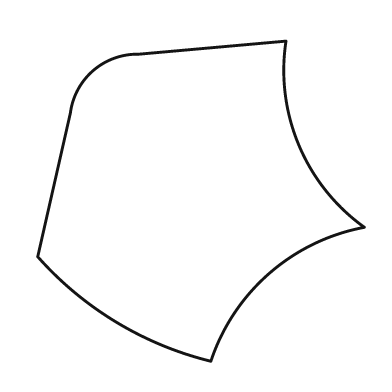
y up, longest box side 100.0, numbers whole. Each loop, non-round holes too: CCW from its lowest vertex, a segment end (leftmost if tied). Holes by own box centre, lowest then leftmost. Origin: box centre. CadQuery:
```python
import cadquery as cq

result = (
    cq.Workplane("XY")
    .moveTo(3.0, -49.0)
    .threePointArc((21.0, -22.0), (50.0, -8.0))
    .threePointArc((30.0, 17.0), (26.0, 49.0))
    .lineTo(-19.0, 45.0)
    .threePointArc((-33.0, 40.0), (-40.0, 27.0))
    .lineTo(-50.0, -17.0)
    .threePointArc((-26.0, -37.0), (3.0, -49.0))
    .close()
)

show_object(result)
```